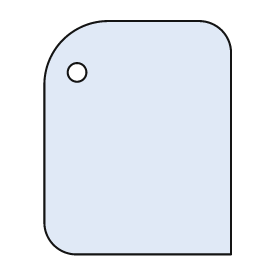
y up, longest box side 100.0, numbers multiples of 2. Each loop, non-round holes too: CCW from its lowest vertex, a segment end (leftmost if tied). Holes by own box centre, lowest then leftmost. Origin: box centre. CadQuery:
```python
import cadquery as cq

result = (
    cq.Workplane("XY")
    .moveTo(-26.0, -50.0)
    .lineTo(40.0, -50.0)
    .lineTo(40.0, 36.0)
    .threePointArc((36.0, 46.0), (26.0, 50.0))
    .lineTo(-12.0, 50.0)
    .threePointArc((-32.0, 42.0), (-40.0, 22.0))
    .lineTo(-40.0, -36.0)
    .threePointArc((-36.0, -46.0), (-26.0, -50.0))
    .close()
    .moveTo(-26.0, 28.0)
    .circle(4.0)
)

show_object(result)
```